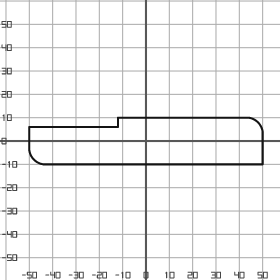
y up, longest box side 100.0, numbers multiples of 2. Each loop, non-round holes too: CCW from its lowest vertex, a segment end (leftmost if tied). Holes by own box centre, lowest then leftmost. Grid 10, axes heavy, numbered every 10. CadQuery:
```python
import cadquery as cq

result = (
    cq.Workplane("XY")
    .moveTo(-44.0, -10.0)
    .lineTo(50.0, -10.0)
    .lineTo(50.0, 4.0)
    .threePointArc((48.0, 8.0), (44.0, 10.0))
    .lineTo(-12.0, 10.0)
    .lineTo(-12.0, 6.0)
    .lineTo(-50.0, 6.0)
    .lineTo(-50.0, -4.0)
    .threePointArc((-48.0, -8.0), (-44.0, -10.0))
    .close()
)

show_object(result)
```